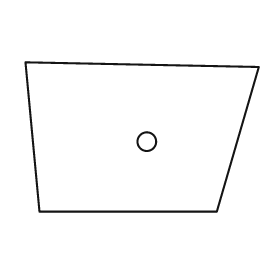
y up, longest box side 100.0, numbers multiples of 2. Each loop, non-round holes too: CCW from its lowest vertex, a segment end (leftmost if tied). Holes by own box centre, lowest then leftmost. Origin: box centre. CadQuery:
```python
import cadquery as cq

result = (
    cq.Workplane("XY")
    .moveTo(-44.0, -32.0)
    .lineTo(32.0, -32.0)
    .lineTo(50.0, 30.0)
    .lineTo(-50.0, 32.0)
    .close()
    .moveTo(2.0, -2.0)
    .circle(4.0)
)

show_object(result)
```